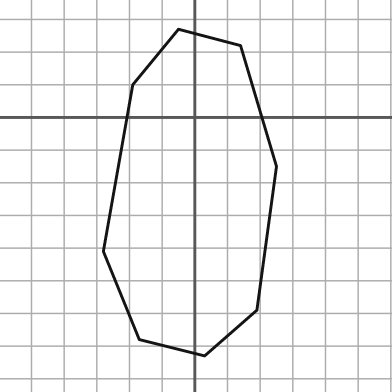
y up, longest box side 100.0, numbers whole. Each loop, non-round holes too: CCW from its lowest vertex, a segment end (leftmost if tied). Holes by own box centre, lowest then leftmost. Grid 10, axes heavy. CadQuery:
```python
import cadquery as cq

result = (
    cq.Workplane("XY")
    .moveTo(3.0, -73.0)
    .lineTo(19.0, -59.0)
    .lineTo(25.0, -15.0)
    .lineTo(14.0, 22.0)
    .lineTo(-5.0, 27.0)
    .lineTo(-19.0, 10.0)
    .lineTo(-28.0, -41.0)
    .lineTo(-17.0, -68.0)
    .close()
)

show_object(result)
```